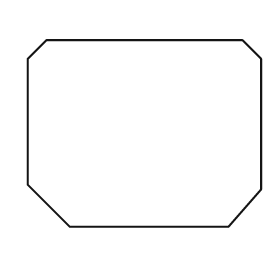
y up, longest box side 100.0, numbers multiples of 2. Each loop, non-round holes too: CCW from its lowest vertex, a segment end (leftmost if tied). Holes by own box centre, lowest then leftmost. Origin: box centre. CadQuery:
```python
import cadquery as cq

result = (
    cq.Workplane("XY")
    .moveTo(-32.0, -40.0)
    .lineTo(36.0, -40.0)
    .lineTo(50.0, -24.0)
    .lineTo(50.0, 32.0)
    .lineTo(42.0, 40.0)
    .lineTo(-42.0, 40.0)
    .lineTo(-50.0, 32.0)
    .lineTo(-50.0, -22.0)
    .close()
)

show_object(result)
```